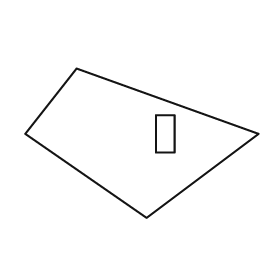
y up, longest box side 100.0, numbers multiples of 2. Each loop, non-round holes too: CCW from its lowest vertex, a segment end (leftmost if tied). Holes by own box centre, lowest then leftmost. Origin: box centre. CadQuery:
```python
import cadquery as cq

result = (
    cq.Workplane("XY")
    .moveTo(2.0, -32.0)
    .lineTo(50.0, 4.0)
    .lineTo(-28.0, 32.0)
    .lineTo(-50.0, 4.0)
    .close()
    .moveTo(6.0, -4.0)
    .lineTo(14.0, -4.0)
    .lineTo(14.0, 12.0)
    .lineTo(6.0, 12.0)
    .close()
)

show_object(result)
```